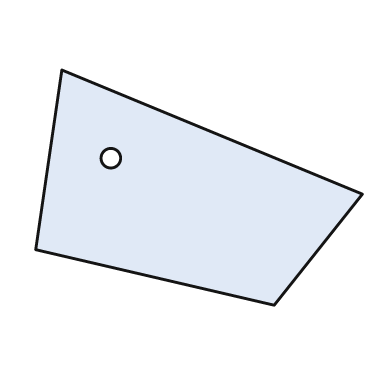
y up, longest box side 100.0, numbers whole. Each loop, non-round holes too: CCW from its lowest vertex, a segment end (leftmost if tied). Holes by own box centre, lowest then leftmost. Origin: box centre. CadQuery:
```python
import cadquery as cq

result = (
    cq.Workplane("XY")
    .moveTo(23.0, -36.0)
    .lineTo(50.0, -2.0)
    .lineTo(-42.0, 36.0)
    .lineTo(-50.0, -19.0)
    .close()
    .moveTo(-27.0, 9.0)
    .circle(3.0)
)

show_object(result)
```